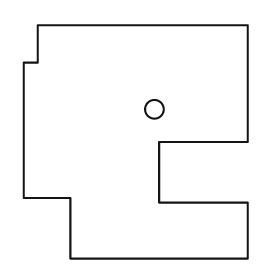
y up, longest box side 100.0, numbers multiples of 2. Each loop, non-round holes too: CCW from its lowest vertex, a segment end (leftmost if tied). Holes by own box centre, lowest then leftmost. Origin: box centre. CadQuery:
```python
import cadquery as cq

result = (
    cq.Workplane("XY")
    .moveTo(-28.0, -50.0)
    .lineTo(48.0, -50.0)
    .lineTo(48.0, -26.0)
    .lineTo(10.0, -26.0)
    .lineTo(10.0, 0.0)
    .lineTo(48.0, 0.0)
    .lineTo(48.0, 50.0)
    .lineTo(-42.0, 50.0)
    .lineTo(-42.0, 34.0)
    .lineTo(-48.0, 34.0)
    .lineTo(-48.0, -24.0)
    .lineTo(-28.0, -24.0)
    .close()
    .moveTo(8.0, 14.0)
    .circle(4.0)
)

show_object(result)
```